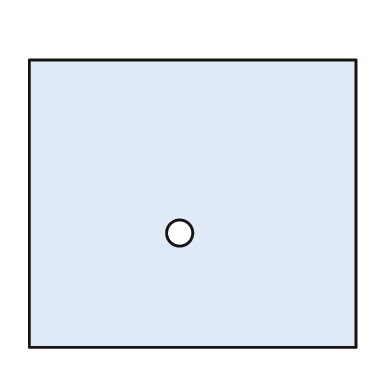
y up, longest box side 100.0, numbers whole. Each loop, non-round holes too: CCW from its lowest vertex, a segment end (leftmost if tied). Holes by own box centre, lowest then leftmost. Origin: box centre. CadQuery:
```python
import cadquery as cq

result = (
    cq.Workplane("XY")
    .moveTo(-50.0, -44.0)
    .lineTo(50.0, -44.0)
    .lineTo(50.0, 44.0)
    .lineTo(-50.0, 44.0)
    .close()
    .moveTo(-4.0, -9.0)
    .circle(4.0)
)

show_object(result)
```